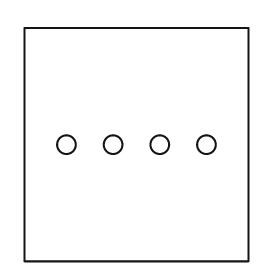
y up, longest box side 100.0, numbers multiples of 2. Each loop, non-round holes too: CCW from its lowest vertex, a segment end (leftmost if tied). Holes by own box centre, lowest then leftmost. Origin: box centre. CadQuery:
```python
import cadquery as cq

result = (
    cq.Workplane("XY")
    .moveTo(-48.0, -50.0)
    .lineTo(48.0, -50.0)
    .lineTo(48.0, 50.0)
    .lineTo(-48.0, 50.0)
    .close()
    .moveTo(-30.0, 0.0)
    .circle(4.0)
    .moveTo(-10.0, 0.0)
    .circle(4.0)
    .moveTo(10.0, 0.0)
    .circle(4.0)
    .moveTo(30.0, 0.0)
    .circle(4.0)
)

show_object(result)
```